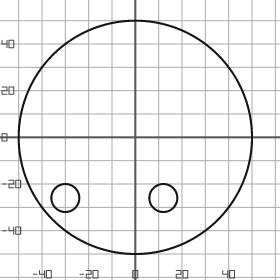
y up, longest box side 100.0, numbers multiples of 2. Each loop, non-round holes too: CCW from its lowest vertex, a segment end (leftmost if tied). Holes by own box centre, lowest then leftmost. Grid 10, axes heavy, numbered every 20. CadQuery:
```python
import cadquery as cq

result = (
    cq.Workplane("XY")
    .moveTo(0.0, 0.0)
    .circle(50.0)
    .moveTo(-30.0, -26.0)
    .circle(6.0)
    .moveTo(12.0, -26.0)
    .circle(6.0)
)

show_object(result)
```